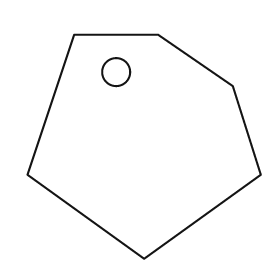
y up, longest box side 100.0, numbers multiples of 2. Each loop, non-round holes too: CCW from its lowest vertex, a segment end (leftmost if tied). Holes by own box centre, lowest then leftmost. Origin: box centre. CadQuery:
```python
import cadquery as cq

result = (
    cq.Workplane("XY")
    .moveTo(0.0, -48.0)
    .lineTo(50.0, -12.0)
    .lineTo(38.0, 26.0)
    .lineTo(6.0, 48.0)
    .lineTo(-30.0, 48.0)
    .lineTo(-50.0, -12.0)
    .close()
    .moveTo(-12.0, 32.0)
    .circle(6.0)
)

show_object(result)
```